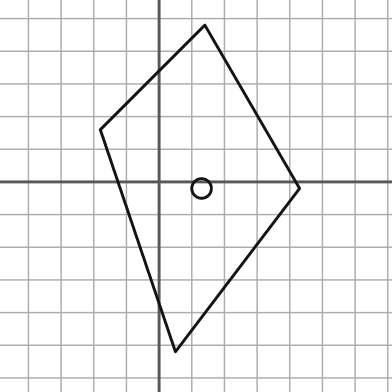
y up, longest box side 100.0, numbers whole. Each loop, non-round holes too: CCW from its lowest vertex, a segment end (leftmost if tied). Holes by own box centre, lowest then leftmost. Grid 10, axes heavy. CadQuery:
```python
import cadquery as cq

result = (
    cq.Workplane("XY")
    .moveTo(5.0, -52.0)
    .lineTo(43.0, -2.0)
    .lineTo(14.0, 48.0)
    .lineTo(-18.0, 16.0)
    .close()
    .moveTo(13.0, -2.0)
    .circle(3.0)
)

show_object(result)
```